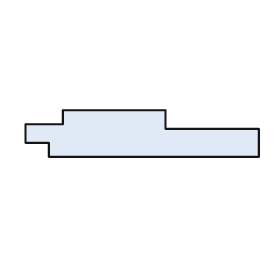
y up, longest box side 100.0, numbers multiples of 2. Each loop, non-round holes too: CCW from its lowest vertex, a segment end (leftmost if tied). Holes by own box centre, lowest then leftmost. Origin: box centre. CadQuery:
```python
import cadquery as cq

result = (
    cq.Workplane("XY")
    .moveTo(-40.0, -10.0)
    .lineTo(50.0, -10.0)
    .lineTo(50.0, 2.0)
    .lineTo(10.0, 2.0)
    .lineTo(10.0, 10.0)
    .lineTo(-34.0, 10.0)
    .lineTo(-34.0, 4.0)
    .lineTo(-50.0, 4.0)
    .lineTo(-50.0, -4.0)
    .lineTo(-40.0, -4.0)
    .close()
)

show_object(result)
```